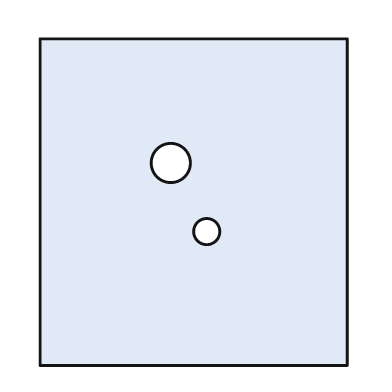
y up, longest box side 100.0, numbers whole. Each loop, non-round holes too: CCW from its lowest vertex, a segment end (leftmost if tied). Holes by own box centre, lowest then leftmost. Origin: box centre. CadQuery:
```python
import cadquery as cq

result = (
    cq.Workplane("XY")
    .moveTo(-47.0, -50.0)
    .lineTo(47.0, -50.0)
    .lineTo(47.0, 50.0)
    .lineTo(-47.0, 50.0)
    .close()
    .moveTo(4.0, -9.0)
    .circle(4.0)
    .moveTo(-7.0, 12.0)
    .circle(6.0)
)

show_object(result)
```